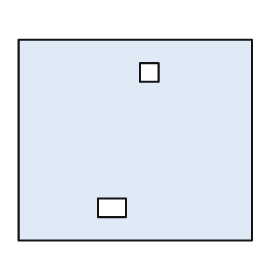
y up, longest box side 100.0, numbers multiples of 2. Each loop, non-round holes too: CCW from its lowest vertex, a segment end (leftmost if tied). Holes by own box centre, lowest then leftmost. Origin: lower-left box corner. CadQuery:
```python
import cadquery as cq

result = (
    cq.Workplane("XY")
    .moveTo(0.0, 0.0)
    .lineTo(100.0, 0.0)
    .lineTo(100.0, 86.0)
    .lineTo(0.0, 86.0)
    .close()
    .moveTo(34.0, 10.0)
    .lineTo(46.0, 10.0)
    .lineTo(46.0, 18.0)
    .lineTo(34.0, 18.0)
    .close()
    .moveTo(52.0, 68.0)
    .lineTo(60.0, 68.0)
    .lineTo(60.0, 76.0)
    .lineTo(52.0, 76.0)
    .close()
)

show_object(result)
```